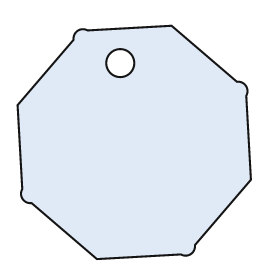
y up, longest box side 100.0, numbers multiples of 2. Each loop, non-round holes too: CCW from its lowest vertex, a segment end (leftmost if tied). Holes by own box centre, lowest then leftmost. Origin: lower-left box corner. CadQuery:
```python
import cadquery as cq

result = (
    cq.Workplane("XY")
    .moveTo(34.0, 0.0)
    .lineTo(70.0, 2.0)
    .threePointArc((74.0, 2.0), (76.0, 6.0))
    .lineTo(100.0, 34.0)
    .lineTo(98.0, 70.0)
    .threePointArc((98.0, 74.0), (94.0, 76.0))
    .lineTo(66.0, 100.0)
    .lineTo(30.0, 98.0)
    .threePointArc((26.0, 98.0), (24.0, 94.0))
    .lineTo(0.0, 66.0)
    .lineTo(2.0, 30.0)
    .threePointArc((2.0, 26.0), (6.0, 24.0))
    .close()
    .moveTo(44.0, 84.0)
    .circle(6.0)
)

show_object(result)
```